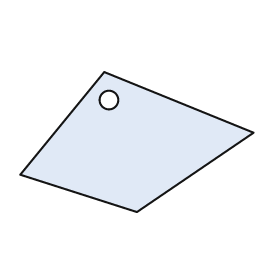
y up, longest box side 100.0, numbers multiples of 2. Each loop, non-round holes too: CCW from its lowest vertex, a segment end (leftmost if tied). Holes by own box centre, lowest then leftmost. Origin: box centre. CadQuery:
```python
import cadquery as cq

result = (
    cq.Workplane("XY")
    .moveTo(0.0, -30.0)
    .lineTo(50.0, 4.0)
    .lineTo(-14.0, 30.0)
    .lineTo(-50.0, -14.0)
    .close()
    .moveTo(-12.0, 18.0)
    .circle(4.0)
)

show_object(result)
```